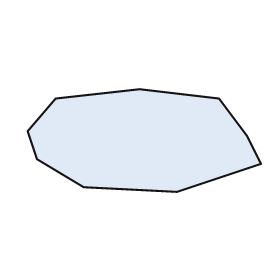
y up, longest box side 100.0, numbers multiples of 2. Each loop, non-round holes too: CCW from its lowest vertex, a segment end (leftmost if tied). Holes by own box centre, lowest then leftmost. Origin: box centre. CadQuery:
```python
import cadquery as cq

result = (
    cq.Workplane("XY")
    .moveTo(14.0, -22.0)
    .lineTo(50.0, -10.0)
    .lineTo(44.0, 2.0)
    .lineTo(32.0, 18.0)
    .lineTo(-2.0, 22.0)
    .lineTo(-38.0, 18.0)
    .lineTo(-50.0, 4.0)
    .lineTo(-46.0, -8.0)
    .lineTo(-26.0, -20.0)
    .close()
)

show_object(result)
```